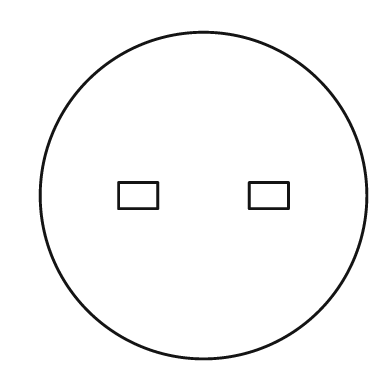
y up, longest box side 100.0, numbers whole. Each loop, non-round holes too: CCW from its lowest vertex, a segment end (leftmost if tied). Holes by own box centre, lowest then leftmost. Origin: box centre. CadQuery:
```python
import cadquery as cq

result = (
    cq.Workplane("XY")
    .moveTo(0.0, 0.0)
    .circle(50.0)
    .moveTo(-26.0, -4.0)
    .lineTo(-14.0, -4.0)
    .lineTo(-14.0, 4.0)
    .lineTo(-26.0, 4.0)
    .close()
    .moveTo(14.0, -4.0)
    .lineTo(26.0, -4.0)
    .lineTo(26.0, 4.0)
    .lineTo(14.0, 4.0)
    .close()
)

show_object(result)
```